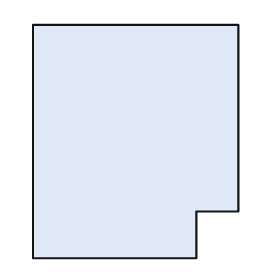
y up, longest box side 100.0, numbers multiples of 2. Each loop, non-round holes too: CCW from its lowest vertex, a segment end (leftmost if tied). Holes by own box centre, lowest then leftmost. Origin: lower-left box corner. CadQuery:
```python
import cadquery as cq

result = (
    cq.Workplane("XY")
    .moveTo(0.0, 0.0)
    .lineTo(70.0, 0.0)
    .lineTo(70.0, 20.0)
    .lineTo(88.0, 20.0)
    .lineTo(88.0, 100.0)
    .lineTo(0.0, 100.0)
    .close()
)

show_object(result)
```